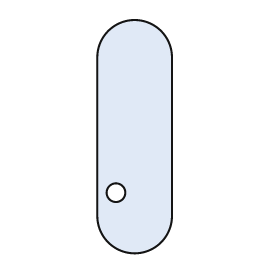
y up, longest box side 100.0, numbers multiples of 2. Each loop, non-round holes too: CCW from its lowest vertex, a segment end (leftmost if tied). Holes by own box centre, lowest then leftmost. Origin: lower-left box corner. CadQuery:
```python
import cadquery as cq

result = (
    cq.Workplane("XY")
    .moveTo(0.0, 16.0)
    .threePointArc((16.0, 0.0), (32.0, 16.0))
    .lineTo(32.0, 84.0)
    .threePointArc((16.0, 100.0), (0.0, 84.0))
    .close()
    .moveTo(8.0, 26.0)
    .circle(4.0)
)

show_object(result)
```